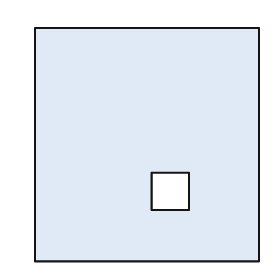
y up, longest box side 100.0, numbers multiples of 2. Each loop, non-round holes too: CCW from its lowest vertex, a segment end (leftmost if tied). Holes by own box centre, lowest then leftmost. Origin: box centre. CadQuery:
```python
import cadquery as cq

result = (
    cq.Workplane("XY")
    .moveTo(-48.0, -50.0)
    .lineTo(48.0, -50.0)
    .lineTo(48.0, 50.0)
    .lineTo(-48.0, 50.0)
    .close()
    .moveTo(2.0, -28.0)
    .lineTo(18.0, -28.0)
    .lineTo(18.0, -12.0)
    .lineTo(2.0, -12.0)
    .close()
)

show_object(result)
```